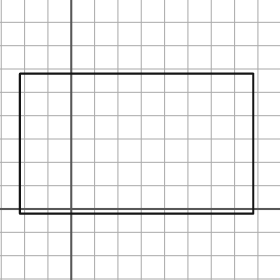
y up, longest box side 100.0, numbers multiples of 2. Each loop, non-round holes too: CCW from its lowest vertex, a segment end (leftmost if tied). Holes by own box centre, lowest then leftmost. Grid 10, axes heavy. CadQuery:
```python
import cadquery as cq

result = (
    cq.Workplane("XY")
    .moveTo(-22.0, -2.0)
    .lineTo(78.0, -2.0)
    .lineTo(78.0, 58.0)
    .lineTo(-22.0, 58.0)
    .close()
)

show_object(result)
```